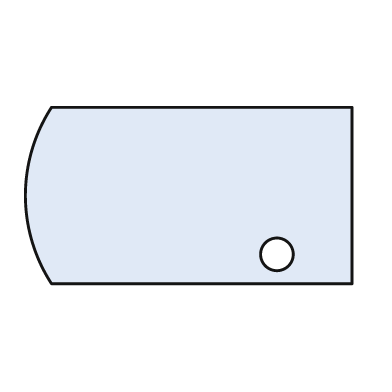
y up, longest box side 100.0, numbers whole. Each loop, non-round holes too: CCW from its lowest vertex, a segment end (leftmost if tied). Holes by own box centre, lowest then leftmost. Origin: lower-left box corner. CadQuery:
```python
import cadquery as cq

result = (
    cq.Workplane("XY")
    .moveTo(8.0, 0.0)
    .lineTo(100.0, 0.0)
    .lineTo(100.0, 54.0)
    .lineTo(8.0, 54.0)
    .threePointArc((0.0, 27.0), (8.0, 0.0))
    .close()
    .moveTo(77.0, 9.0)
    .circle(5.0)
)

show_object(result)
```